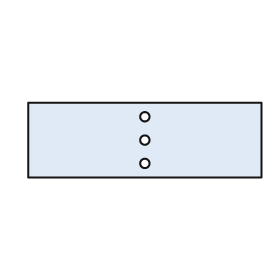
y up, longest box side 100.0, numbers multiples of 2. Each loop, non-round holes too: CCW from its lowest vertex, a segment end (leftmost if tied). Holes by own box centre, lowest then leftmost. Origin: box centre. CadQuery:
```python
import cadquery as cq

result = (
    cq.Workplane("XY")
    .moveTo(-50.0, -16.0)
    .lineTo(50.0, -16.0)
    .lineTo(50.0, 16.0)
    .lineTo(-50.0, 16.0)
    .close()
    .moveTo(0.0, -10.0)
    .circle(2.0)
    .moveTo(0.0, 0.0)
    .circle(2.0)
    .moveTo(0.0, 10.0)
    .circle(2.0)
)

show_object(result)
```